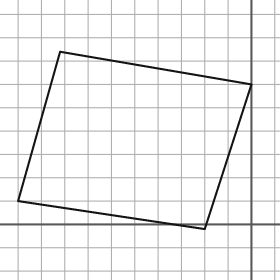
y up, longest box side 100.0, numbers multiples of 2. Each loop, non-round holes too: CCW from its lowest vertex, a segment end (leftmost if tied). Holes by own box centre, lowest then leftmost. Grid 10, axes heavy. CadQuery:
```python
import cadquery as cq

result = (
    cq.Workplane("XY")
    .moveTo(-20.0, -2.0)
    .lineTo(0.0, 60.0)
    .lineTo(-82.0, 74.0)
    .lineTo(-100.0, 10.0)
    .close()
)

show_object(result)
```